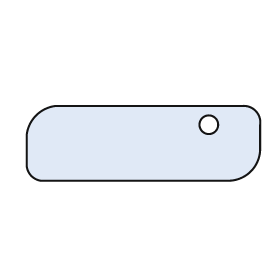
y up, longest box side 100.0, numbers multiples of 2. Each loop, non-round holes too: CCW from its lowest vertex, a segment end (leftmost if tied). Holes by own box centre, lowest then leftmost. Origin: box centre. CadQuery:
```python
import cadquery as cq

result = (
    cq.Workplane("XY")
    .moveTo(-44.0, -16.0)
    .lineTo(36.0, -16.0)
    .threePointArc((46.0, -12.0), (50.0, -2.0))
    .lineTo(50.0, 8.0)
    .threePointArc((48.0, 14.0), (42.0, 16.0))
    .lineTo(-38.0, 16.0)
    .threePointArc((-46.0, 12.0), (-50.0, 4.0))
    .lineTo(-50.0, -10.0)
    .threePointArc((-48.0, -14.0), (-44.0, -16.0))
    .close()
    .moveTo(28.0, 8.0)
    .circle(4.0)
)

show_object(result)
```